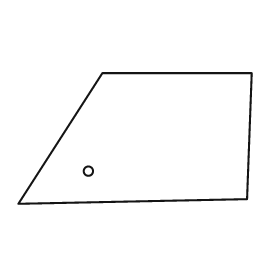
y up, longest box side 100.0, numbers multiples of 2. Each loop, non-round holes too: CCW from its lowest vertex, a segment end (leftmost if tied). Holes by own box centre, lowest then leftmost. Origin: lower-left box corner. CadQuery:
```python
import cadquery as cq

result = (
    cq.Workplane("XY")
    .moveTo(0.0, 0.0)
    .lineTo(98.0, 2.0)
    .lineTo(100.0, 56.0)
    .lineTo(36.0, 56.0)
    .close()
    .moveTo(30.0, 14.0)
    .circle(2.0)
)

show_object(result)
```